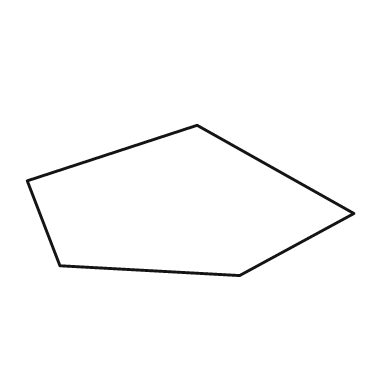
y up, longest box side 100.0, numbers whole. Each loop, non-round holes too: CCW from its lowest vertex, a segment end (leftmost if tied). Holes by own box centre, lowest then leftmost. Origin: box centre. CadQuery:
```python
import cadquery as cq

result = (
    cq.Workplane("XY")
    .moveTo(15.0, -23.0)
    .lineTo(50.0, -4.0)
    .lineTo(2.0, 23.0)
    .lineTo(-50.0, 6.0)
    .lineTo(-40.0, -20.0)
    .close()
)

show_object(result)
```